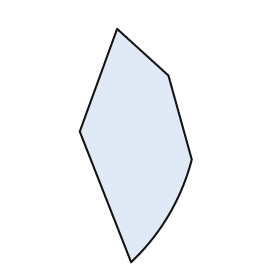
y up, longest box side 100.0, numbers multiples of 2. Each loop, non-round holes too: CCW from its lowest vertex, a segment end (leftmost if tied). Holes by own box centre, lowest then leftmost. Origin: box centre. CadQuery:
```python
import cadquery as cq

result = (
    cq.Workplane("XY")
    .moveTo(-2.0, -50.0)
    .threePointArc((14.0, -30.0), (24.0, -6.0))
    .lineTo(14.0, 30.0)
    .lineTo(-8.0, 50.0)
    .lineTo(-24.0, 6.0)
    .close()
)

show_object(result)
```